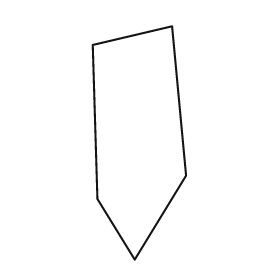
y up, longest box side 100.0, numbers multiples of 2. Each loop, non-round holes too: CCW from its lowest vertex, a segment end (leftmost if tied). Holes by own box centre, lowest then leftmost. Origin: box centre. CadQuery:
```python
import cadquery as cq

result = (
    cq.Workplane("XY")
    .moveTo(-2.0, -50.0)
    .lineTo(20.0, -14.0)
    .lineTo(14.0, 50.0)
    .lineTo(-20.0, 42.0)
    .lineTo(-18.0, -24.0)
    .close()
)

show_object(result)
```